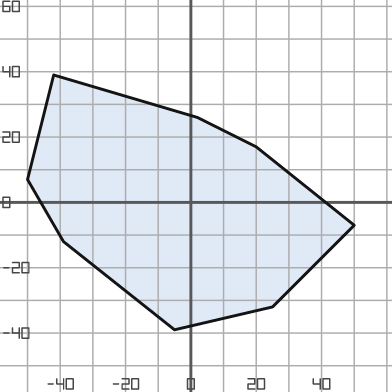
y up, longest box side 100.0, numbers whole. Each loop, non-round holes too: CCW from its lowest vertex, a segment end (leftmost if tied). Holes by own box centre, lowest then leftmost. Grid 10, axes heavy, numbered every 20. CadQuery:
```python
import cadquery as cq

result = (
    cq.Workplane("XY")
    .moveTo(-5.0, -39.0)
    .lineTo(25.0, -32.0)
    .lineTo(50.0, -7.0)
    .lineTo(20.0, 17.0)
    .lineTo(2.0, 26.0)
    .lineTo(-42.0, 39.0)
    .lineTo(-50.0, 7.0)
    .lineTo(-39.0, -12.0)
    .close()
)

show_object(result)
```